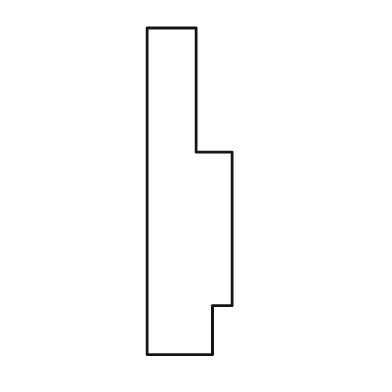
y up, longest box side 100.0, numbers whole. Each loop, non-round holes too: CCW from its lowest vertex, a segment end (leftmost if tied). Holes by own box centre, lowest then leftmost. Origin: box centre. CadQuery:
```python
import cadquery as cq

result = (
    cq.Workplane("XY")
    .moveTo(-13.0, -50.0)
    .lineTo(7.0, -50.0)
    .lineTo(7.0, -35.0)
    .lineTo(13.0, -35.0)
    .lineTo(13.0, 12.0)
    .lineTo(2.0, 12.0)
    .lineTo(2.0, 50.0)
    .lineTo(-13.0, 50.0)
    .close()
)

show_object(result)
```